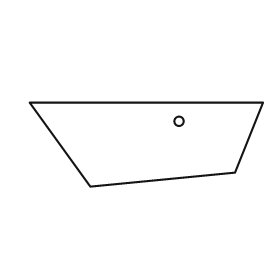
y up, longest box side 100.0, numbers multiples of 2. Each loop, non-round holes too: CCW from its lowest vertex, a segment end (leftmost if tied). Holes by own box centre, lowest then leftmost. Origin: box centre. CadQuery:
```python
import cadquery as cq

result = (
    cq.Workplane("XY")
    .moveTo(-24.0, -18.0)
    .lineTo(38.0, -12.0)
    .lineTo(50.0, 18.0)
    .lineTo(-50.0, 18.0)
    .close()
    .moveTo(14.0, 10.0)
    .circle(2.0)
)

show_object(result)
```